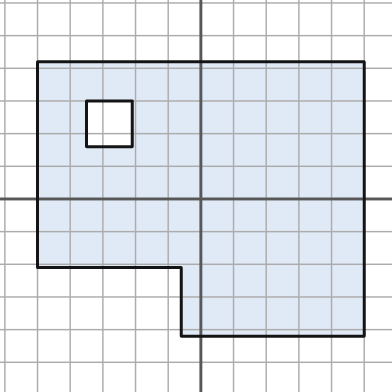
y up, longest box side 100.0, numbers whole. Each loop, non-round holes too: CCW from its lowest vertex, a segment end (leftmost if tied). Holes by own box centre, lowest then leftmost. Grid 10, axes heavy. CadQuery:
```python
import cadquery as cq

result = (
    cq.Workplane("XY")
    .moveTo(-6.0, -42.0)
    .lineTo(50.0, -42.0)
    .lineTo(50.0, 42.0)
    .lineTo(-50.0, 42.0)
    .lineTo(-50.0, -21.0)
    .lineTo(-6.0, -21.0)
    .close()
    .moveTo(-35.0, 16.0)
    .lineTo(-21.0, 16.0)
    .lineTo(-21.0, 30.0)
    .lineTo(-35.0, 30.0)
    .close()
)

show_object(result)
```